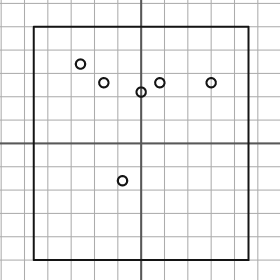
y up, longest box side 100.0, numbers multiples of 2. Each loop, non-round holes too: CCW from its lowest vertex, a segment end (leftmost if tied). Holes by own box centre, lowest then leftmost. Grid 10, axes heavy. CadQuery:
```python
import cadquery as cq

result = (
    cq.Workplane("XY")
    .moveTo(-46.0, -50.0)
    .lineTo(46.0, -50.0)
    .lineTo(46.0, 50.0)
    .lineTo(-46.0, 50.0)
    .close()
    .moveTo(-8.0, -16.0)
    .circle(2.0)
    .moveTo(0.0, 22.0)
    .circle(2.0)
    .moveTo(-16.0, 26.0)
    .circle(2.0)
    .moveTo(8.0, 26.0)
    .circle(2.0)
    .moveTo(30.0, 26.0)
    .circle(2.0)
    .moveTo(-26.0, 34.0)
    .circle(2.0)
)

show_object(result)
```